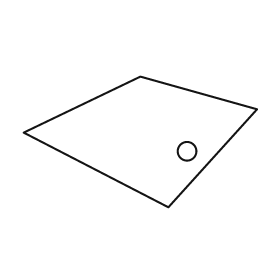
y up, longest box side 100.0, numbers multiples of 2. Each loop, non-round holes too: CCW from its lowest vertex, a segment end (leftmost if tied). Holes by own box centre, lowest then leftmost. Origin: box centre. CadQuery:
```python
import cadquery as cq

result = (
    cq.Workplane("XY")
    .moveTo(12.0, -28.0)
    .lineTo(50.0, 14.0)
    .lineTo(0.0, 28.0)
    .lineTo(-50.0, 4.0)
    .close()
    .moveTo(20.0, -4.0)
    .circle(4.0)
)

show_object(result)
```